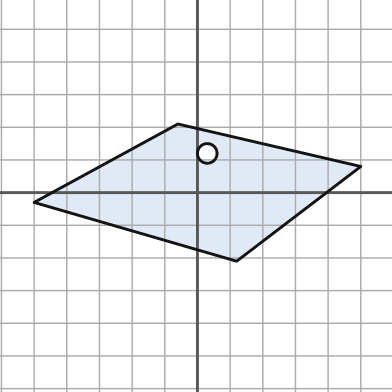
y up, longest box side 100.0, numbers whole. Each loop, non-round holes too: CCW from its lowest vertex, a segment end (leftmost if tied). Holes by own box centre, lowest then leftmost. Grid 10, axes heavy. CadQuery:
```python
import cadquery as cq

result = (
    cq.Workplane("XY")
    .moveTo(12.0, -21.0)
    .lineTo(50.0, 8.0)
    .lineTo(-6.0, 21.0)
    .lineTo(-50.0, -3.0)
    .close()
    .moveTo(3.0, 12.0)
    .circle(3.0)
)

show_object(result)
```